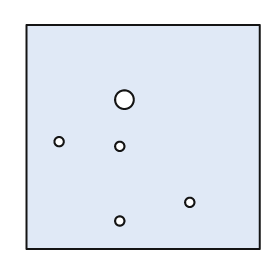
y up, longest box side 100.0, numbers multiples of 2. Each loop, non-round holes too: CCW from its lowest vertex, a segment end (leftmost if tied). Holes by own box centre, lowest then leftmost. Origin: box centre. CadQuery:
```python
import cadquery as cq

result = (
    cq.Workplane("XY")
    .moveTo(-50.0, -48.0)
    .lineTo(50.0, -48.0)
    .lineTo(50.0, 48.0)
    .lineTo(-50.0, 48.0)
    .close()
    .moveTo(-10.0, -36.0)
    .circle(2.0)
    .moveTo(20.0, -28.0)
    .circle(2.0)
    .moveTo(-10.0, -4.0)
    .circle(2.0)
    .moveTo(-36.0, -2.0)
    .circle(2.0)
    .moveTo(-8.0, 16.0)
    .circle(4.0)
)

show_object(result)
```